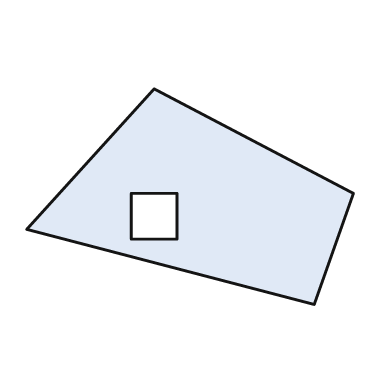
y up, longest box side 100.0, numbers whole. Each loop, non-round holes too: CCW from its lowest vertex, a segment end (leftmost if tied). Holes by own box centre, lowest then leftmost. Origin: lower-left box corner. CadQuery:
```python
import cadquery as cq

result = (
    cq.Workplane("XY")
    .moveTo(88.0, 0.0)
    .lineTo(100.0, 34.0)
    .lineTo(39.0, 66.0)
    .lineTo(0.0, 23.0)
    .close()
    .moveTo(32.0, 20.0)
    .lineTo(46.0, 20.0)
    .lineTo(46.0, 34.0)
    .lineTo(32.0, 34.0)
    .close()
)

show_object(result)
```